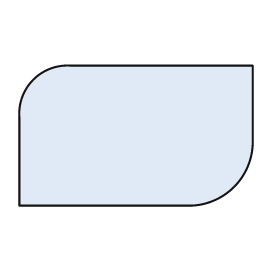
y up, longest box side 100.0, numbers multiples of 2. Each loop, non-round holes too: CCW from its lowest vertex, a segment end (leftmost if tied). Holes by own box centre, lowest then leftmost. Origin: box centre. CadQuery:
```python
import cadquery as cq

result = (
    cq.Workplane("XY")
    .moveTo(-50.0, -30.0)
    .lineTo(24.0, -30.0)
    .threePointArc((42.0, -22.0), (50.0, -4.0))
    .lineTo(50.0, 30.0)
    .lineTo(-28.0, 30.0)
    .threePointArc((-44.0, 24.0), (-50.0, 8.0))
    .close()
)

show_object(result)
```